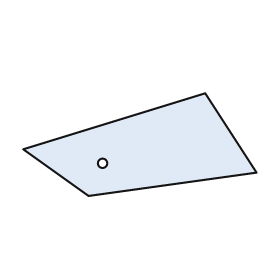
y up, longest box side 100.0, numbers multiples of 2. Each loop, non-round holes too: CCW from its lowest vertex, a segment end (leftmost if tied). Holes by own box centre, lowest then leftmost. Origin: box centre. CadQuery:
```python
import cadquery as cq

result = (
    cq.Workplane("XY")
    .moveTo(-22.0, -22.0)
    .lineTo(50.0, -12.0)
    .lineTo(28.0, 22.0)
    .lineTo(-50.0, -2.0)
    .close()
    .moveTo(-16.0, -8.0)
    .circle(2.0)
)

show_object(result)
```